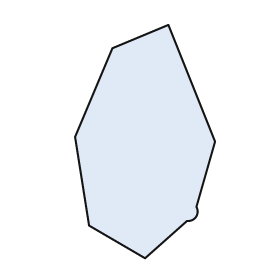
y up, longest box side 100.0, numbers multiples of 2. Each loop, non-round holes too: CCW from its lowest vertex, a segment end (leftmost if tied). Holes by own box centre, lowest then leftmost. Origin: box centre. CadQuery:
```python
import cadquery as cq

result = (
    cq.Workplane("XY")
    .moveTo(0.0, -50.0)
    .lineTo(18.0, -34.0)
    .threePointArc((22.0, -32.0), (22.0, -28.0))
    .lineTo(30.0, 0.0)
    .lineTo(10.0, 50.0)
    .lineTo(-14.0, 40.0)
    .lineTo(-30.0, 2.0)
    .lineTo(-24.0, -36.0)
    .close()
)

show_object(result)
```